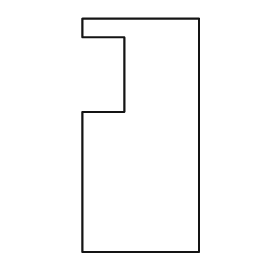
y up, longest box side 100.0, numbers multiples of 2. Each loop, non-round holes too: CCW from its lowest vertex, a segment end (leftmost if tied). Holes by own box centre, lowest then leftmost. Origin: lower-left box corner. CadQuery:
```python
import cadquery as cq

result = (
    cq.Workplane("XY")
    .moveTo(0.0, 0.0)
    .lineTo(50.0, 0.0)
    .lineTo(50.0, 100.0)
    .lineTo(0.0, 100.0)
    .lineTo(0.0, 92.0)
    .lineTo(18.0, 92.0)
    .lineTo(18.0, 60.0)
    .lineTo(0.0, 60.0)
    .close()
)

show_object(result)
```